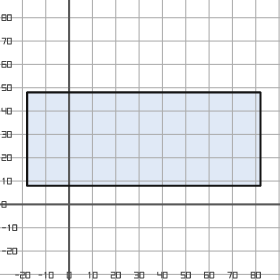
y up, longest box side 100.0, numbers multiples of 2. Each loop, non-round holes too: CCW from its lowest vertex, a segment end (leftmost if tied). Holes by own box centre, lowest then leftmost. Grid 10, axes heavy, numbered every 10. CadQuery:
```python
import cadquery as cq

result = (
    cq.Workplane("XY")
    .moveTo(-18.0, 8.0)
    .lineTo(82.0, 8.0)
    .lineTo(82.0, 48.0)
    .lineTo(-18.0, 48.0)
    .close()
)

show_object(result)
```